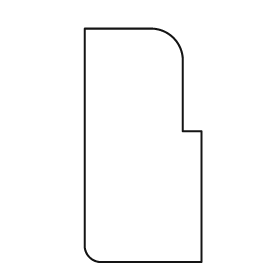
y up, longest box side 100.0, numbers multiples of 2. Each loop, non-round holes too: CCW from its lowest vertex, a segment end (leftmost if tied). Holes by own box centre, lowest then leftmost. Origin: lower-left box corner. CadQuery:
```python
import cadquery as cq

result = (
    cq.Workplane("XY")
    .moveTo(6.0, 0.0)
    .lineTo(50.0, 0.0)
    .lineTo(50.0, 56.0)
    .lineTo(42.0, 56.0)
    .lineTo(42.0, 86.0)
    .threePointArc((38.0, 96.0), (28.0, 100.0))
    .lineTo(0.0, 100.0)
    .lineTo(0.0, 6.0)
    .threePointArc((2.0, 2.0), (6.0, 0.0))
    .close()
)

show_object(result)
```